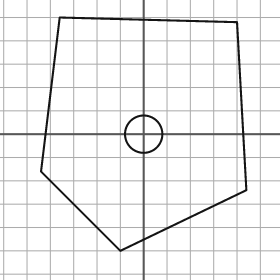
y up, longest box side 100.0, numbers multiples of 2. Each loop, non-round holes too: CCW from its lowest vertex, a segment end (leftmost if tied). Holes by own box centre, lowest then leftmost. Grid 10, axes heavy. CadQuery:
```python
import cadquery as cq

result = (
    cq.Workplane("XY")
    .moveTo(-10.0, -50.0)
    .lineTo(44.0, -24.0)
    .lineTo(40.0, 48.0)
    .lineTo(-36.0, 50.0)
    .lineTo(-44.0, -16.0)
    .close()
    .moveTo(0.0, 0.0)
    .circle(8.0)
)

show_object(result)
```